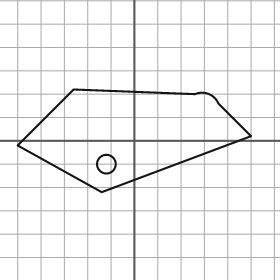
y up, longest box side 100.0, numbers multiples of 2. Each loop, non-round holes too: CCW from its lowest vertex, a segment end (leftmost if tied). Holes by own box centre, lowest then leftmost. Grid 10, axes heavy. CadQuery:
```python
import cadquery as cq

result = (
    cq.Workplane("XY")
    .moveTo(-14.0, -22.0)
    .lineTo(50.0, 2.0)
    .lineTo(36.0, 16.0)
    .threePointArc((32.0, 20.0), (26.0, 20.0))
    .lineTo(-26.0, 22.0)
    .lineTo(-50.0, -2.0)
    .close()
    .moveTo(-12.0, -10.0)
    .circle(4.0)
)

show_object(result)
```